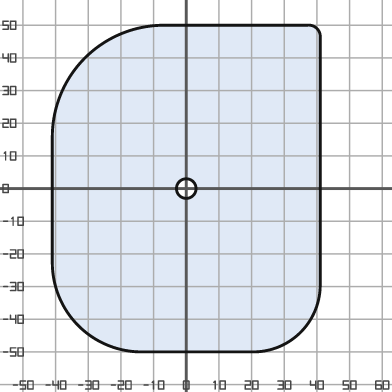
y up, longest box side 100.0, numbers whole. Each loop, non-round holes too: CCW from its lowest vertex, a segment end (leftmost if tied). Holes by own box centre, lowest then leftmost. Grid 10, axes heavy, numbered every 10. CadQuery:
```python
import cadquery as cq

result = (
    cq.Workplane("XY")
    .moveTo(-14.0, -50.0)
    .lineTo(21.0, -50.0)
    .threePointArc((35.0, -44.0), (41.0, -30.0))
    .lineTo(41.0, 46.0)
    .threePointArc((40.0, 49.0), (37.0, 50.0))
    .lineTo(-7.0, 50.0)
    .threePointArc((-31.0, 40.0), (-41.0, 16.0))
    .lineTo(-41.0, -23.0)
    .threePointArc((-33.0, -42.0), (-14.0, -50.0))
    .close()
    .moveTo(0.0, 0.0)
    .circle(3.0)
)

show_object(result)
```